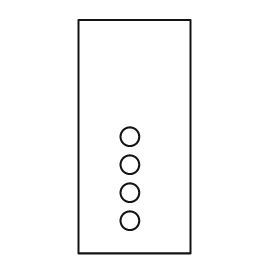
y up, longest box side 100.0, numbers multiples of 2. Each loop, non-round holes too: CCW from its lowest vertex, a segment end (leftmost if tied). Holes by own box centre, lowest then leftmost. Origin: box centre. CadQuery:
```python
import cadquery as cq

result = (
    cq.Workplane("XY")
    .moveTo(-24.0, -50.0)
    .lineTo(24.0, -50.0)
    .lineTo(24.0, 50.0)
    .lineTo(-24.0, 50.0)
    .close()
    .moveTo(-2.0, -36.0)
    .circle(4.0)
    .moveTo(-2.0, -24.0)
    .circle(4.0)
    .moveTo(-2.0, -12.0)
    .circle(4.0)
    .moveTo(-2.0, 0.0)
    .circle(4.0)
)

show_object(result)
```